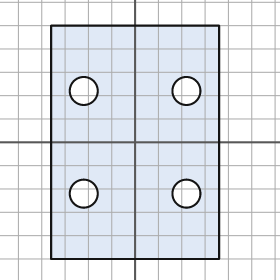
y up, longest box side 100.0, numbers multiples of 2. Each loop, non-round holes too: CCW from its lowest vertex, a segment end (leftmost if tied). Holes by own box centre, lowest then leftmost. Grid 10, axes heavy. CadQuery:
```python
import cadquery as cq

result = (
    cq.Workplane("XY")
    .moveTo(-36.0, -50.0)
    .lineTo(36.0, -50.0)
    .lineTo(36.0, 50.0)
    .lineTo(-36.0, 50.0)
    .close()
    .moveTo(-22.0, -22.0)
    .circle(6.0)
    .moveTo(22.0, -22.0)
    .circle(6.0)
    .moveTo(-22.0, 22.0)
    .circle(6.0)
    .moveTo(22.0, 22.0)
    .circle(6.0)
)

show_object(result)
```